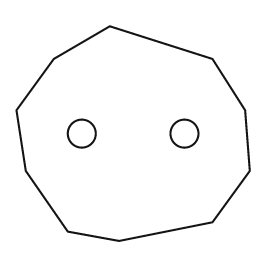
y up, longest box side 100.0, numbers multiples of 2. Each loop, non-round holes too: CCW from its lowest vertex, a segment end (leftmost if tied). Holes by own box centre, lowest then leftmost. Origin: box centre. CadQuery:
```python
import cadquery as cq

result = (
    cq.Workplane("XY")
    .moveTo(-6.0, -46.0)
    .lineTo(34.0, -38.0)
    .lineTo(50.0, -16.0)
    .lineTo(48.0, 10.0)
    .lineTo(34.0, 32.0)
    .lineTo(-10.0, 46.0)
    .lineTo(-34.0, 32.0)
    .lineTo(-50.0, 10.0)
    .lineTo(-46.0, -16.0)
    .lineTo(-28.0, -42.0)
    .close()
    .moveTo(-22.0, 0.0)
    .circle(6.0)
    .moveTo(22.0, 0.0)
    .circle(6.0)
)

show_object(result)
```